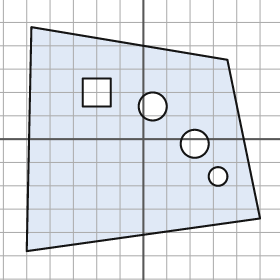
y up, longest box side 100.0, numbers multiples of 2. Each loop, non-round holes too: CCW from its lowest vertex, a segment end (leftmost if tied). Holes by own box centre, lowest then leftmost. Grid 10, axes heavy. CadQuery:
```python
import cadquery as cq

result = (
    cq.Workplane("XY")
    .moveTo(-50.0, -48.0)
    .lineTo(50.0, -34.0)
    .lineTo(36.0, 34.0)
    .lineTo(-48.0, 48.0)
    .close()
    .moveTo(32.0, -16.0)
    .circle(4.0)
    .moveTo(22.0, -2.0)
    .circle(6.0)
    .moveTo(4.0, 14.0)
    .circle(6.0)
    .moveTo(-26.0, 14.0)
    .lineTo(-14.0, 14.0)
    .lineTo(-14.0, 26.0)
    .lineTo(-26.0, 26.0)
    .close()
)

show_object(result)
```